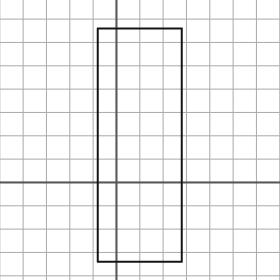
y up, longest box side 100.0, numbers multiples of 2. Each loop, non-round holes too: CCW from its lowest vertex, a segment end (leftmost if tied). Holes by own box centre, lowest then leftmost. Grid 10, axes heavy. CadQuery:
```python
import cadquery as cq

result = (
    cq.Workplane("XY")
    .moveTo(-8.0, -34.0)
    .lineTo(28.0, -34.0)
    .lineTo(28.0, 66.0)
    .lineTo(-8.0, 66.0)
    .close()
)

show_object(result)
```